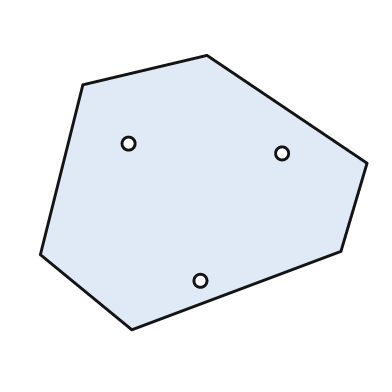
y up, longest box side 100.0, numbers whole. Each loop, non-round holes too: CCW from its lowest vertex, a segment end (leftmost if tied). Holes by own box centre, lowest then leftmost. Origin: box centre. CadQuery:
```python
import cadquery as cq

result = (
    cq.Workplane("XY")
    .moveTo(-22.0, -42.0)
    .lineTo(42.0, -18.0)
    .lineTo(50.0, 9.0)
    .lineTo(1.0, 42.0)
    .lineTo(-37.0, 33.0)
    .lineTo(-50.0, -19.0)
    .close()
    .moveTo(-1.0, -27.0)
    .circle(2.0)
    .moveTo(24.0, 12.0)
    .circle(2.0)
    .moveTo(-23.0, 15.0)
    .circle(2.0)
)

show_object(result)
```